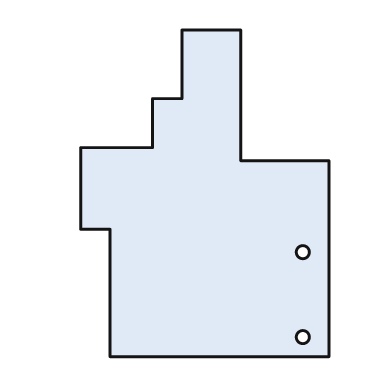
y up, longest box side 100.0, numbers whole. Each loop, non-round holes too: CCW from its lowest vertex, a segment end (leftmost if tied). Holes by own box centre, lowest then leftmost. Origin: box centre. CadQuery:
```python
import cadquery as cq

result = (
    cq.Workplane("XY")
    .moveTo(-29.0, -50.0)
    .lineTo(38.0, -50.0)
    .lineTo(38.0, 10.0)
    .lineTo(11.0, 10.0)
    .lineTo(11.0, 50.0)
    .lineTo(-7.0, 50.0)
    .lineTo(-7.0, 29.0)
    .lineTo(-16.0, 29.0)
    .lineTo(-16.0, 14.0)
    .lineTo(-38.0, 14.0)
    .lineTo(-38.0, -11.0)
    .lineTo(-29.0, -11.0)
    .close()
    .moveTo(30.0, -44.0)
    .circle(2.0)
    .moveTo(30.0, -18.0)
    .circle(2.0)
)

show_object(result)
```